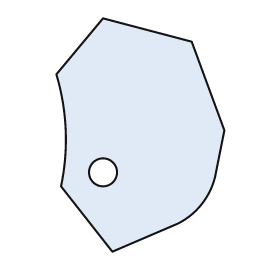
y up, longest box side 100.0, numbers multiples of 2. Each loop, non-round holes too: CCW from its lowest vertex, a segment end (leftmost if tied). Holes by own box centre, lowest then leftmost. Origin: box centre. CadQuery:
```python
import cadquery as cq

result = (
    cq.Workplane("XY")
    .moveTo(-12.0, -50.0)
    .lineTo(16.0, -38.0)
    .threePointArc((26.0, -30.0), (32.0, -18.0))
    .lineTo(36.0, 2.0)
    .lineTo(22.0, 40.0)
    .lineTo(-16.0, 50.0)
    .lineTo(-36.0, 26.0)
    .threePointArc((-32.0, 2.0), (-34.0, -22.0))
    .close()
    .moveTo(-16.0, -16.0)
    .circle(6.0)
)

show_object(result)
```